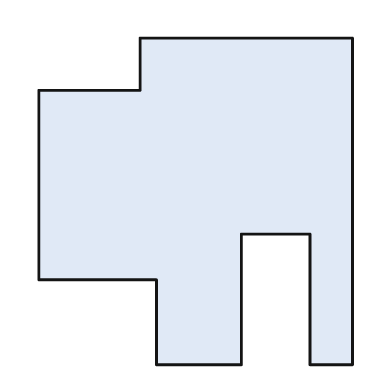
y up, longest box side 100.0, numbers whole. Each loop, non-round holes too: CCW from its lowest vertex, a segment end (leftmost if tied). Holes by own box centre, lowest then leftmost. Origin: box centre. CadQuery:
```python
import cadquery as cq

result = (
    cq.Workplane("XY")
    .moveTo(-12.0, -50.0)
    .lineTo(14.0, -50.0)
    .lineTo(14.0, -10.0)
    .lineTo(35.0, -10.0)
    .lineTo(35.0, -50.0)
    .lineTo(48.0, -50.0)
    .lineTo(48.0, 50.0)
    .lineTo(-17.0, 50.0)
    .lineTo(-17.0, 34.0)
    .lineTo(-48.0, 34.0)
    .lineTo(-48.0, -24.0)
    .lineTo(-12.0, -24.0)
    .close()
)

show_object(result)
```